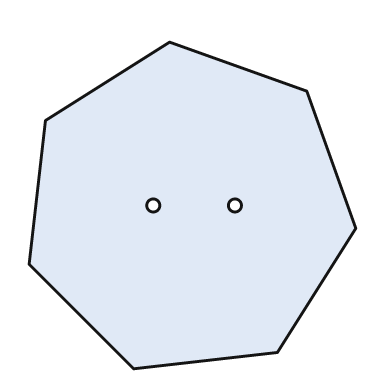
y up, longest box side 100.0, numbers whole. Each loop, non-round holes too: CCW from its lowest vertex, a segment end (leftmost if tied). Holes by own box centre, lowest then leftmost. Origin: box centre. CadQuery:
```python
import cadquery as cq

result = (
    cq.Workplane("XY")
    .moveTo(-18.0, -50.0)
    .lineTo(26.0, -45.0)
    .lineTo(50.0, -7.0)
    .lineTo(35.0, 35.0)
    .lineTo(-7.0, 50.0)
    .lineTo(-45.0, 26.0)
    .lineTo(-50.0, -18.0)
    .close()
    .moveTo(-12.0, 0.0)
    .circle(2.0)
    .moveTo(13.0, 0.0)
    .circle(2.0)
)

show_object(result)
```